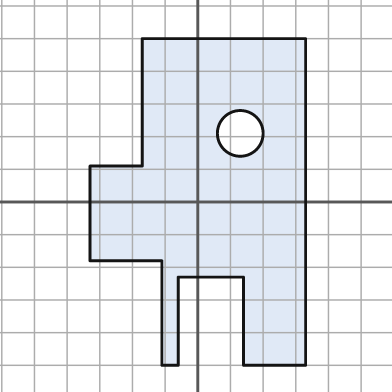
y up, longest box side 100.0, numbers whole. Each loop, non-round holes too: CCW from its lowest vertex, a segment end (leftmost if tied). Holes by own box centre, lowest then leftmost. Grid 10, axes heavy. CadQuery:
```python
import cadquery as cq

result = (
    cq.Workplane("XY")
    .moveTo(-11.0, -50.0)
    .lineTo(-6.0, -50.0)
    .lineTo(-6.0, -23.0)
    .lineTo(14.0, -23.0)
    .lineTo(14.0, -50.0)
    .lineTo(33.0, -50.0)
    .lineTo(33.0, 50.0)
    .lineTo(-17.0, 50.0)
    .lineTo(-17.0, 11.0)
    .lineTo(-33.0, 11.0)
    .lineTo(-33.0, -18.0)
    .lineTo(-11.0, -18.0)
    .close()
    .moveTo(13.0, 21.0)
    .circle(7.0)
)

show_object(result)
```